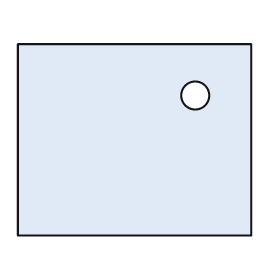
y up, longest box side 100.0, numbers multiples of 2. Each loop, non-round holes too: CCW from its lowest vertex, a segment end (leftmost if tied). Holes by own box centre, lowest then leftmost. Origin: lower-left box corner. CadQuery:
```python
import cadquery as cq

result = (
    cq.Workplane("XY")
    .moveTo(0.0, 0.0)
    .lineTo(100.0, 0.0)
    .lineTo(100.0, 82.0)
    .lineTo(0.0, 82.0)
    .close()
    .moveTo(76.0, 60.0)
    .circle(6.0)
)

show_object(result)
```